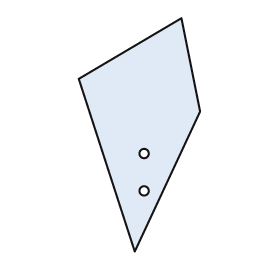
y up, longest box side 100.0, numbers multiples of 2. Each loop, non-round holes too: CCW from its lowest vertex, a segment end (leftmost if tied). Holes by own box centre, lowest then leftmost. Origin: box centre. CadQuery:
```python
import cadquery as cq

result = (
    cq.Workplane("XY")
    .moveTo(-2.0, -50.0)
    .lineTo(26.0, 10.0)
    .lineTo(18.0, 50.0)
    .lineTo(-26.0, 24.0)
    .close()
    .moveTo(2.0, -24.0)
    .circle(2.0)
    .moveTo(2.0, -8.0)
    .circle(2.0)
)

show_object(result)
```